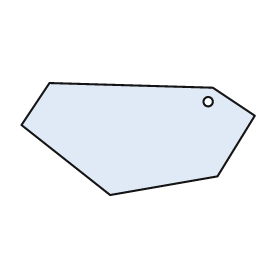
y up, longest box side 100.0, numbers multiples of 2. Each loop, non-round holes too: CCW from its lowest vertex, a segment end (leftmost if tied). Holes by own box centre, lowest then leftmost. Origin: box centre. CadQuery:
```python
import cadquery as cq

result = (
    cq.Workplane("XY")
    .moveTo(-12.0, -24.0)
    .lineTo(34.0, -16.0)
    .lineTo(50.0, 10.0)
    .lineTo(32.0, 22.0)
    .lineTo(-38.0, 24.0)
    .lineTo(-50.0, 6.0)
    .close()
    .moveTo(30.0, 16.0)
    .circle(2.0)
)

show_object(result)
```